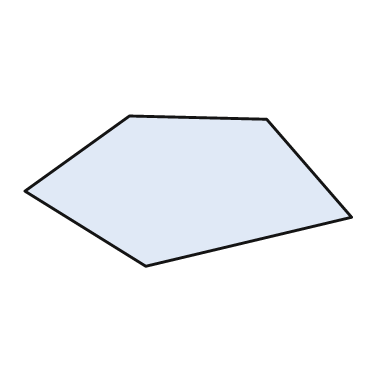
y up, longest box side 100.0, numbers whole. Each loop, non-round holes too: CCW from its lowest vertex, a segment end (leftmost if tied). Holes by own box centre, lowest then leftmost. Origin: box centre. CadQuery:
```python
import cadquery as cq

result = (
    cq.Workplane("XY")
    .moveTo(-13.0, -23.0)
    .lineTo(50.0, -8.0)
    .lineTo(24.0, 22.0)
    .lineTo(-18.0, 23.0)
    .lineTo(-50.0, 0.0)
    .close()
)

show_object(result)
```